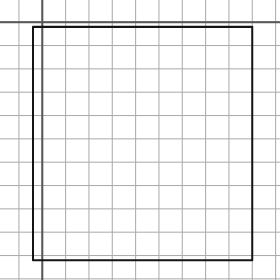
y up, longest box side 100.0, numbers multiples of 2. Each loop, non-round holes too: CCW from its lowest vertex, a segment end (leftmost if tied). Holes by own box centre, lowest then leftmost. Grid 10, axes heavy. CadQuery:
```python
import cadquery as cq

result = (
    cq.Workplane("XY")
    .moveTo(-4.0, -102.0)
    .lineTo(90.0, -102.0)
    .lineTo(90.0, -2.0)
    .lineTo(-4.0, -2.0)
    .close()
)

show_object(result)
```